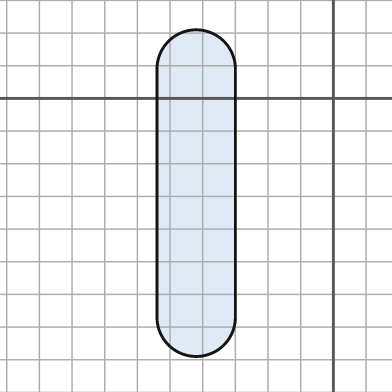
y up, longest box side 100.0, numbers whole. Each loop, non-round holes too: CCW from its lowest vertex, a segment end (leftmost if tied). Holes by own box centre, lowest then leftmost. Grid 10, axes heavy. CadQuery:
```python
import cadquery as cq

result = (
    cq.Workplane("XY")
    .moveTo(-54.0, -67.0)
    .threePointArc((-42.0, -79.0), (-30.0, -67.0))
    .lineTo(-30.0, 9.0)
    .threePointArc((-42.0, 21.0), (-54.0, 9.0))
    .close()
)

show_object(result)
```